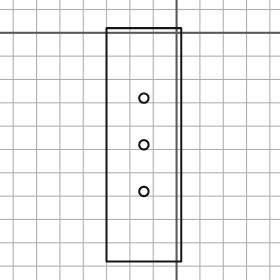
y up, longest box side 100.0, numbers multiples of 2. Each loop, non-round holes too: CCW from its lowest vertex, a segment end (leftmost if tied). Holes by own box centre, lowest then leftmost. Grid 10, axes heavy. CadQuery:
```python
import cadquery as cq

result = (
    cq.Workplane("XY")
    .moveTo(-30.0, -98.0)
    .lineTo(2.0, -98.0)
    .lineTo(2.0, 2.0)
    .lineTo(-30.0, 2.0)
    .close()
    .moveTo(-14.0, -68.0)
    .circle(2.0)
    .moveTo(-14.0, -48.0)
    .circle(2.0)
    .moveTo(-14.0, -28.0)
    .circle(2.0)
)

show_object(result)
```